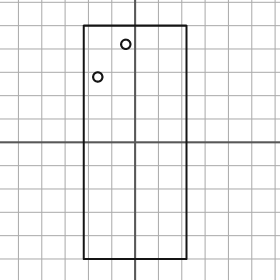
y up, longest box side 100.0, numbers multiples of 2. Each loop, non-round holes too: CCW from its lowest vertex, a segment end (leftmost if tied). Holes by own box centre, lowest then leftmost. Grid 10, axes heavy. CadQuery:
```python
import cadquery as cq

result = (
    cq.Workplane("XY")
    .moveTo(-22.0, -50.0)
    .lineTo(22.0, -50.0)
    .lineTo(22.0, 50.0)
    .lineTo(-22.0, 50.0)
    .close()
    .moveTo(-16.0, 28.0)
    .circle(2.0)
    .moveTo(-4.0, 42.0)
    .circle(2.0)
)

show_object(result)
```